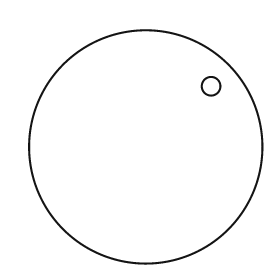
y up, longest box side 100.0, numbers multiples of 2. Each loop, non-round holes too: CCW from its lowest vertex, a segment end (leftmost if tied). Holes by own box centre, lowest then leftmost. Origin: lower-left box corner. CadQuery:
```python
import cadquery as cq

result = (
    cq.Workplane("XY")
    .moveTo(50.0, 50.0)
    .circle(50.0)
    .moveTo(78.0, 76.0)
    .circle(4.0)
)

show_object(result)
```